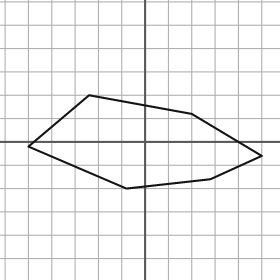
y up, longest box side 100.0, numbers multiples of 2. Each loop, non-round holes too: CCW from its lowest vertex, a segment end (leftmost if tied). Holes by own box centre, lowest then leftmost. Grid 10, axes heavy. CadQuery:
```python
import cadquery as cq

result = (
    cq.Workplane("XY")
    .moveTo(-8.0, -20.0)
    .lineTo(28.0, -16.0)
    .lineTo(50.0, -6.0)
    .lineTo(20.0, 12.0)
    .lineTo(-24.0, 20.0)
    .lineTo(-50.0, -2.0)
    .close()
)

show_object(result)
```